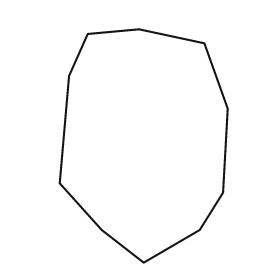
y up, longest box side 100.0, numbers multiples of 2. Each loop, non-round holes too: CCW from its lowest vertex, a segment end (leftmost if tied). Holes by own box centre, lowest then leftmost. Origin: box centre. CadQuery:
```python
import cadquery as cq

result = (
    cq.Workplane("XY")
    .moveTo(0.0, -50.0)
    .lineTo(24.0, -36.0)
    .lineTo(34.0, -20.0)
    .lineTo(36.0, 16.0)
    .lineTo(26.0, 44.0)
    .lineTo(-2.0, 50.0)
    .lineTo(-24.0, 48.0)
    .lineTo(-32.0, 30.0)
    .lineTo(-36.0, -16.0)
    .lineTo(-18.0, -36.0)
    .close()
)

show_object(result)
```